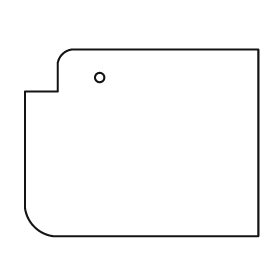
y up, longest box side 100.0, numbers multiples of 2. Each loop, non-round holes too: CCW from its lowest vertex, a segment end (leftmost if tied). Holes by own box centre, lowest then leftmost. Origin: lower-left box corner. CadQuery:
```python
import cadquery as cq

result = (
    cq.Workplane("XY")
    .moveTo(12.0, 0.0)
    .lineTo(100.0, 0.0)
    .lineTo(100.0, 80.0)
    .lineTo(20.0, 80.0)
    .threePointArc((16.0, 78.0), (14.0, 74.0))
    .lineTo(14.0, 62.0)
    .lineTo(0.0, 62.0)
    .lineTo(0.0, 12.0)
    .threePointArc((4.0, 4.0), (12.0, 0.0))
    .close()
    .moveTo(32.0, 68.0)
    .circle(2.0)
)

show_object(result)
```